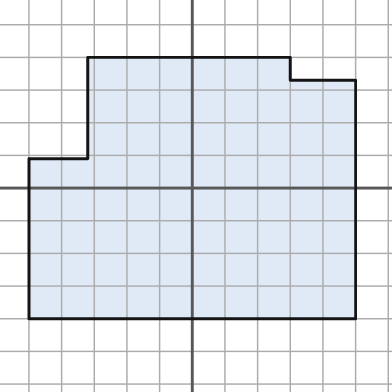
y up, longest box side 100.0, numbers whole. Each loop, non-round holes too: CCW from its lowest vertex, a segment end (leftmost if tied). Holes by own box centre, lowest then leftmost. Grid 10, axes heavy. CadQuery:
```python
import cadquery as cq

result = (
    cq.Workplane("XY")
    .moveTo(-50.0, -40.0)
    .lineTo(50.0, -40.0)
    .lineTo(50.0, 33.0)
    .lineTo(30.0, 33.0)
    .lineTo(30.0, 40.0)
    .lineTo(-32.0, 40.0)
    .lineTo(-32.0, 9.0)
    .lineTo(-50.0, 9.0)
    .close()
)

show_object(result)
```